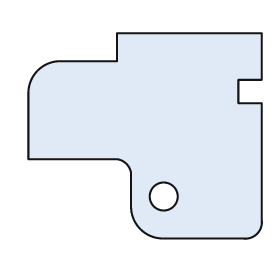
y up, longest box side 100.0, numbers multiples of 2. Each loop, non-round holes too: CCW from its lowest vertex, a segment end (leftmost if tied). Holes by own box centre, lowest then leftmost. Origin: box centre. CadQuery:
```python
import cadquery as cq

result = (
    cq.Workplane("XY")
    .moveTo(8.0, -44.0)
    .lineTo(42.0, -44.0)
    .threePointArc((48.0, -42.0), (50.0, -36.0))
    .lineTo(50.0, 14.0)
    .lineTo(40.0, 14.0)
    .lineTo(40.0, 24.0)
    .lineTo(50.0, 24.0)
    .lineTo(50.0, 44.0)
    .lineTo(-12.0, 44.0)
    .lineTo(-12.0, 32.0)
    .lineTo(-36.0, 32.0)
    .threePointArc((-46.0, 28.0), (-50.0, 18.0))
    .lineTo(-50.0, -10.0)
    .lineTo(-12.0, -10.0)
    .threePointArc((-8.0, -12.0), (-6.0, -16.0))
    .lineTo(-6.0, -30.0)
    .threePointArc((-2.0, -40.0), (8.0, -44.0))
    .close()
    .moveTo(8.0, -26.0)
    .circle(6.0)
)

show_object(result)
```